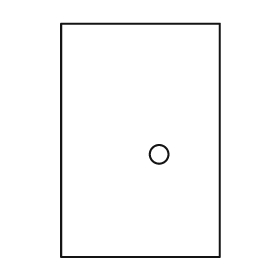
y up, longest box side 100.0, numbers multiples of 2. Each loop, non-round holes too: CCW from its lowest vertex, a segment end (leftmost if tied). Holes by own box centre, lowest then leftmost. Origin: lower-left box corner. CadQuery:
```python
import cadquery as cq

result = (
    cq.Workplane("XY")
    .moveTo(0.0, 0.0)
    .lineTo(68.0, 0.0)
    .lineTo(68.0, 100.0)
    .lineTo(0.0, 100.0)
    .close()
    .moveTo(42.0, 44.0)
    .circle(4.0)
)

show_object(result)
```